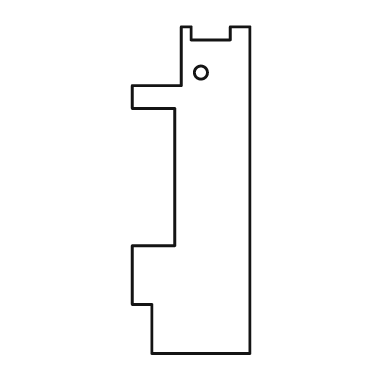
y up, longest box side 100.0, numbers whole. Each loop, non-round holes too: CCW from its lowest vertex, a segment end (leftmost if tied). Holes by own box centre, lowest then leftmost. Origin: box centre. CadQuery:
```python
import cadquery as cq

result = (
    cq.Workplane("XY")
    .moveTo(-12.0, -50.0)
    .lineTo(18.0, -50.0)
    .lineTo(18.0, 50.0)
    .lineTo(12.0, 50.0)
    .lineTo(12.0, 46.0)
    .lineTo(0.0, 46.0)
    .lineTo(0.0, 50.0)
    .lineTo(-3.0, 50.0)
    .lineTo(-3.0, 32.0)
    .lineTo(-18.0, 32.0)
    .lineTo(-18.0, 25.0)
    .lineTo(-5.0, 25.0)
    .lineTo(-5.0, -17.0)
    .lineTo(-18.0, -17.0)
    .lineTo(-18.0, -35.0)
    .lineTo(-12.0, -35.0)
    .close()
    .moveTo(3.0, 36.0)
    .circle(2.0)
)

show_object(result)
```